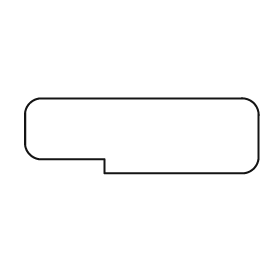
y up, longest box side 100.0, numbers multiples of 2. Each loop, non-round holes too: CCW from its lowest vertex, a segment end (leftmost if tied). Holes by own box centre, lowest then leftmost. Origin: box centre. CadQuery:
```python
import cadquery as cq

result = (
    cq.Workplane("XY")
    .moveTo(-16.0, -16.0)
    .lineTo(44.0, -16.0)
    .threePointArc((48.0, -14.0), (50.0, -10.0))
    .lineTo(50.0, 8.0)
    .threePointArc((48.0, 14.0), (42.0, 16.0))
    .lineTo(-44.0, 16.0)
    .threePointArc((-48.0, 14.0), (-50.0, 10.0))
    .lineTo(-50.0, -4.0)
    .threePointArc((-48.0, -8.0), (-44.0, -10.0))
    .lineTo(-16.0, -10.0)
    .close()
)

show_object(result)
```